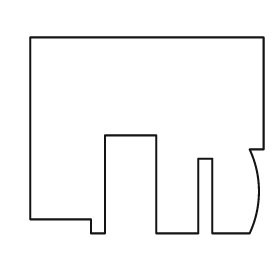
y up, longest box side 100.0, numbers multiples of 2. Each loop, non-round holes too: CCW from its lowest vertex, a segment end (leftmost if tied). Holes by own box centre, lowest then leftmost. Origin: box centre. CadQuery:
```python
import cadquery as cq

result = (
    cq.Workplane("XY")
    .moveTo(-24.0, -42.0)
    .lineTo(-18.0, -42.0)
    .lineTo(-18.0, 0.0)
    .lineTo(4.0, 0.0)
    .lineTo(4.0, -42.0)
    .lineTo(22.0, -42.0)
    .lineTo(22.0, -10.0)
    .lineTo(28.0, -10.0)
    .lineTo(28.0, -42.0)
    .lineTo(44.0, -42.0)
    .threePointArc((48.0, -24.0), (44.0, -6.0))
    .lineTo(50.0, -6.0)
    .lineTo(50.0, 42.0)
    .lineTo(-50.0, 42.0)
    .lineTo(-50.0, -36.0)
    .lineTo(-24.0, -36.0)
    .close()
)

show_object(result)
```